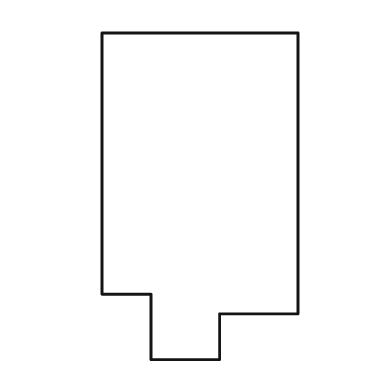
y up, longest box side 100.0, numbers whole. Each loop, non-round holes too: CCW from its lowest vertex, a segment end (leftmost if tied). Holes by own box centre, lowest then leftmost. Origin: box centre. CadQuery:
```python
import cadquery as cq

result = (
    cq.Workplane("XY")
    .moveTo(-15.0, -50.0)
    .lineTo(6.0, -50.0)
    .lineTo(6.0, -36.0)
    .lineTo(30.0, -36.0)
    .lineTo(30.0, 50.0)
    .lineTo(-30.0, 50.0)
    .lineTo(-30.0, -30.0)
    .lineTo(-15.0, -30.0)
    .close()
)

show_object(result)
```